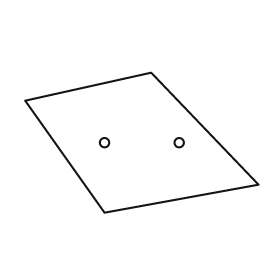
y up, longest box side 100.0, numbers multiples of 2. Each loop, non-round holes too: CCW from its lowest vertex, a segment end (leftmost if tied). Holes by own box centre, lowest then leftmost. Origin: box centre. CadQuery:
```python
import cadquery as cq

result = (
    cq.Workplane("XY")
    .moveTo(-16.0, -30.0)
    .lineTo(50.0, -18.0)
    .lineTo(4.0, 30.0)
    .lineTo(-50.0, 18.0)
    .close()
    .moveTo(-16.0, 0.0)
    .circle(2.0)
    .moveTo(16.0, 0.0)
    .circle(2.0)
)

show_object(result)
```